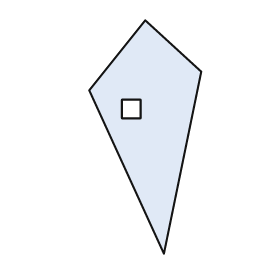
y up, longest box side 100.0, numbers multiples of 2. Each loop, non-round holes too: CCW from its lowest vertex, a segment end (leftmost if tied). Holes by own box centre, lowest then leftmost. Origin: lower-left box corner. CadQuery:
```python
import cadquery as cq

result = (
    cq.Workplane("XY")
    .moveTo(32.0, 0.0)
    .lineTo(48.0, 78.0)
    .lineTo(24.0, 100.0)
    .lineTo(0.0, 70.0)
    .close()
    .moveTo(14.0, 58.0)
    .lineTo(22.0, 58.0)
    .lineTo(22.0, 66.0)
    .lineTo(14.0, 66.0)
    .close()
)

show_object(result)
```